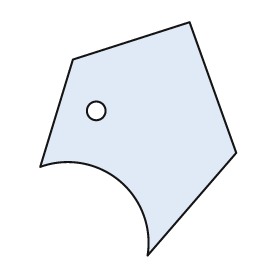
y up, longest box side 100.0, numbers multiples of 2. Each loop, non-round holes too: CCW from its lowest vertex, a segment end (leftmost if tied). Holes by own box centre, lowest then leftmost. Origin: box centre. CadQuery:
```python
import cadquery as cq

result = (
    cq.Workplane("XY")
    .moveTo(4.0, -50.0)
    .lineTo(42.0, -6.0)
    .lineTo(22.0, 50.0)
    .lineTo(-28.0, 34.0)
    .lineTo(-42.0, -12.0)
    .threePointArc((-8.0, -18.0), (4.0, -50.0))
    .close()
    .moveTo(-18.0, 12.0)
    .circle(4.0)
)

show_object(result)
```